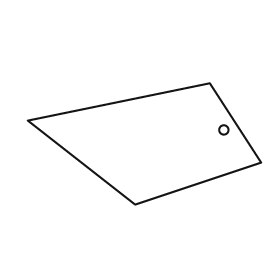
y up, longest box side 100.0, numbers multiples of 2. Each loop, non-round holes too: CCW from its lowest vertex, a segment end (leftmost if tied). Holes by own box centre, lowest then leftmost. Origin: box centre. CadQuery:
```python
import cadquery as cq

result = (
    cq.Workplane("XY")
    .moveTo(-4.0, -26.0)
    .lineTo(50.0, -8.0)
    .lineTo(28.0, 26.0)
    .lineTo(-50.0, 10.0)
    .close()
    .moveTo(34.0, 6.0)
    .circle(2.0)
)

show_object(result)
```